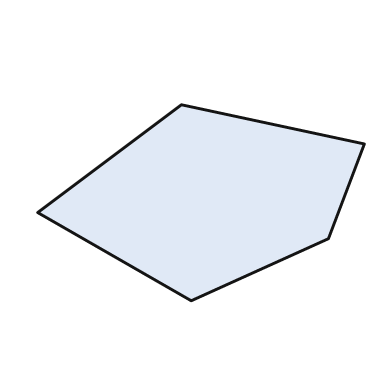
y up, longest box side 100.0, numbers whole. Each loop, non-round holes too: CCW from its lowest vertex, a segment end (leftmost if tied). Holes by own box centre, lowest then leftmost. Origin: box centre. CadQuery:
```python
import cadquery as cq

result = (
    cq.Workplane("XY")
    .moveTo(-3.0, -30.0)
    .lineTo(39.0, -11.0)
    .lineTo(50.0, 18.0)
    .lineTo(-6.0, 30.0)
    .lineTo(-50.0, -3.0)
    .close()
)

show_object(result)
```